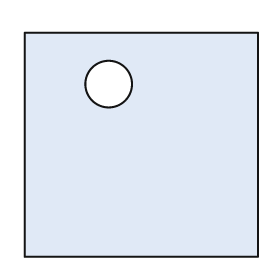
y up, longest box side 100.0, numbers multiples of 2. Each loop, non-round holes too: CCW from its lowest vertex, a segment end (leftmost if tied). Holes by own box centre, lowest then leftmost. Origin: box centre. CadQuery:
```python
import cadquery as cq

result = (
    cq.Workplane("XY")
    .moveTo(-50.0, -48.0)
    .lineTo(50.0, -48.0)
    .lineTo(50.0, 48.0)
    .lineTo(-50.0, 48.0)
    .close()
    .moveTo(-14.0, 26.0)
    .circle(10.0)
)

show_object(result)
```